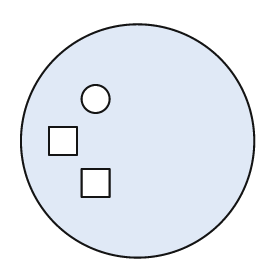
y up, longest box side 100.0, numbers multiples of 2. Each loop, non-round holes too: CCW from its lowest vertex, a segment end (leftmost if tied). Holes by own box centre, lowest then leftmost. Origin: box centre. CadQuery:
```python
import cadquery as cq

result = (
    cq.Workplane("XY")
    .moveTo(0.0, 0.0)
    .circle(50.0)
    .moveTo(-24.0, -24.0)
    .lineTo(-12.0, -24.0)
    .lineTo(-12.0, -12.0)
    .lineTo(-24.0, -12.0)
    .close()
    .moveTo(-38.0, -6.0)
    .lineTo(-26.0, -6.0)
    .lineTo(-26.0, 6.0)
    .lineTo(-38.0, 6.0)
    .close()
    .moveTo(-18.0, 18.0)
    .circle(6.0)
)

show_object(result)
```